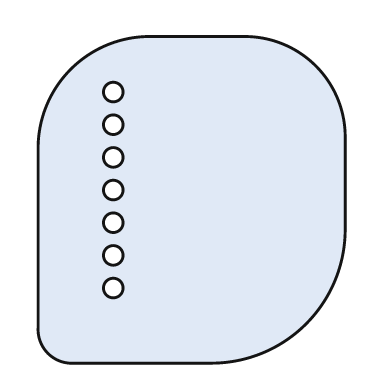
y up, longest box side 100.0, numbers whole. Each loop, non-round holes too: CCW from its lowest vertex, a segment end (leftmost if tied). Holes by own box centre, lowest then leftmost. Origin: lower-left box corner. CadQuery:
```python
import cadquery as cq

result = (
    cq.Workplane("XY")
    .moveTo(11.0, 0.0)
    .lineTo(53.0, 0.0)
    .threePointArc((82.0, 12.0), (94.0, 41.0))
    .lineTo(94.0, 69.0)
    .threePointArc((85.0, 91.0), (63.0, 100.0))
    .lineTo(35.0, 100.0)
    .threePointArc((10.0, 90.0), (0.0, 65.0))
    .lineTo(0.0, 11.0)
    .threePointArc((3.0, 3.0), (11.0, 0.0))
    .close()
    .moveTo(23.0, 23.0)
    .circle(3.0)
    .moveTo(23.0, 33.0)
    .circle(3.0)
    .moveTo(23.0, 43.0)
    .circle(3.0)
    .moveTo(23.0, 53.0)
    .circle(3.0)
    .moveTo(23.0, 63.0)
    .circle(3.0)
    .moveTo(23.0, 73.0)
    .circle(3.0)
    .moveTo(23.0, 83.0)
    .circle(3.0)
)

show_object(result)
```